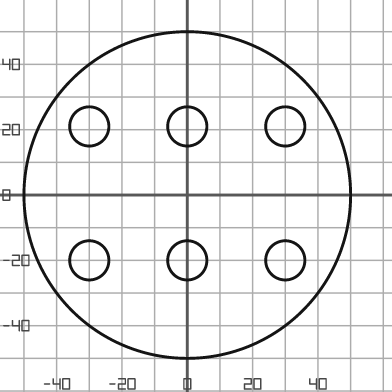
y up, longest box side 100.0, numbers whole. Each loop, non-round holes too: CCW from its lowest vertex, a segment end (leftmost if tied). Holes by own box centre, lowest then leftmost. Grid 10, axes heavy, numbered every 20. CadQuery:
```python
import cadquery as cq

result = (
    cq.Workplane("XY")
    .moveTo(0.0, 0.0)
    .circle(50.0)
    .moveTo(-30.0, -20.0)
    .circle(6.0)
    .moveTo(0.0, -20.0)
    .circle(6.0)
    .moveTo(30.0, -20.0)
    .circle(6.0)
    .moveTo(-30.0, 21.0)
    .circle(6.0)
    .moveTo(0.0, 21.0)
    .circle(6.0)
    .moveTo(30.0, 21.0)
    .circle(6.0)
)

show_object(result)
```